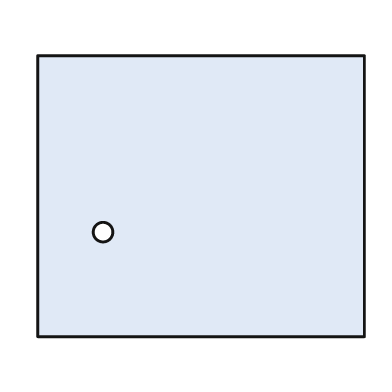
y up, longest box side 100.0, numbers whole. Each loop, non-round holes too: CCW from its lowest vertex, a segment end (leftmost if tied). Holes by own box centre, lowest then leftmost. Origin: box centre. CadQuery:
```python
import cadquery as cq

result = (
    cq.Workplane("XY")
    .moveTo(-50.0, -43.0)
    .lineTo(50.0, -43.0)
    .lineTo(50.0, 43.0)
    .lineTo(-50.0, 43.0)
    .close()
    .moveTo(-30.0, -11.0)
    .circle(3.0)
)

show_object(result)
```